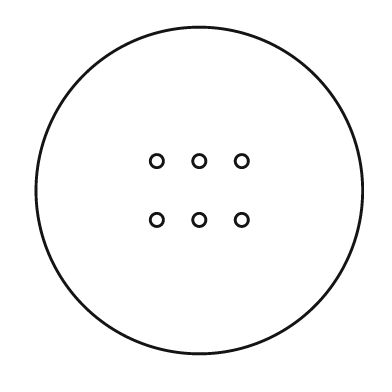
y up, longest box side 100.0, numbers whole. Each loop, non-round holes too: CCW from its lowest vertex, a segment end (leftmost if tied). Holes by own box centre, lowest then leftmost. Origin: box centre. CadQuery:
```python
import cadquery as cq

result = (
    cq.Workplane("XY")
    .moveTo(0.0, 0.0)
    .circle(50.0)
    .moveTo(-13.0, -9.0)
    .circle(2.0)
    .moveTo(0.0, -9.0)
    .circle(2.0)
    .moveTo(13.0, -9.0)
    .circle(2.0)
    .moveTo(-13.0, 9.0)
    .circle(2.0)
    .moveTo(0.0, 9.0)
    .circle(2.0)
    .moveTo(13.0, 9.0)
    .circle(2.0)
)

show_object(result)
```